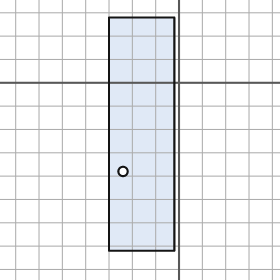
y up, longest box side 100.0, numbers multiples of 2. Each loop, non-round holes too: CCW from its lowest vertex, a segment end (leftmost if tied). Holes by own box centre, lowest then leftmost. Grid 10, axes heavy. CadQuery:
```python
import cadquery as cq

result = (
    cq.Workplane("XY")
    .moveTo(-30.0, -72.0)
    .lineTo(-2.0, -72.0)
    .lineTo(-2.0, 28.0)
    .lineTo(-30.0, 28.0)
    .close()
    .moveTo(-24.0, -38.0)
    .circle(2.0)
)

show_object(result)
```